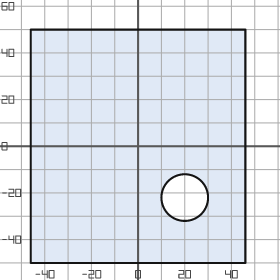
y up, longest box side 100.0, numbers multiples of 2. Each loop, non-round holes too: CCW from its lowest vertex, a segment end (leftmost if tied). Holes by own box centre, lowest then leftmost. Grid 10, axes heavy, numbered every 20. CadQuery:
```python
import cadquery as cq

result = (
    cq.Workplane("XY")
    .moveTo(-46.0, -50.0)
    .lineTo(46.0, -50.0)
    .lineTo(46.0, 50.0)
    .lineTo(-46.0, 50.0)
    .close()
    .moveTo(20.0, -22.0)
    .circle(10.0)
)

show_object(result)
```